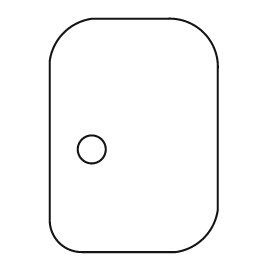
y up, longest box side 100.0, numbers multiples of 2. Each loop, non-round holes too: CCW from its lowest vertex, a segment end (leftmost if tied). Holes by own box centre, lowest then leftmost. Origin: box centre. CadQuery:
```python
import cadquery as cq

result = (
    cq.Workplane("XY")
    .moveTo(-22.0, -50.0)
    .lineTo(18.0, -50.0)
    .threePointArc((30.0, -44.0), (36.0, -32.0))
    .lineTo(36.0, 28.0)
    .threePointArc((30.0, 44.0), (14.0, 50.0))
    .lineTo(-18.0, 50.0)
    .threePointArc((-30.0, 44.0), (-36.0, 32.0))
    .lineTo(-36.0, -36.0)
    .threePointArc((-32.0, -46.0), (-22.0, -50.0))
    .close()
    .moveTo(-18.0, -6.0)
    .circle(6.0)
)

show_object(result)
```